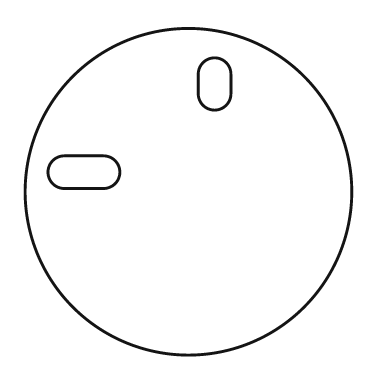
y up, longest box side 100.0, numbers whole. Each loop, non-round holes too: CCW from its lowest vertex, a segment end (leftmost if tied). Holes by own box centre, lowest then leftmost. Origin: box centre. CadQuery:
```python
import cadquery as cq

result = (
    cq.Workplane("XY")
    .moveTo(0.0, 0.0)
    .circle(50.0)
    .moveTo(-38.0, 1.0)
    .lineTo(-26.0, 1.0)
    .threePointArc((-21.0, 6.0), (-26.0, 11.0))
    .lineTo(-38.0, 11.0)
    .threePointArc((-43.0, 6.0), (-38.0, 1.0))
    .close()
    .moveTo(3.0, 30.0)
    .threePointArc((8.0, 25.0), (13.0, 30.0))
    .lineTo(13.0, 36.0)
    .threePointArc((8.0, 41.0), (3.0, 36.0))
    .close()
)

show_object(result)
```